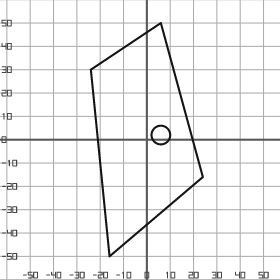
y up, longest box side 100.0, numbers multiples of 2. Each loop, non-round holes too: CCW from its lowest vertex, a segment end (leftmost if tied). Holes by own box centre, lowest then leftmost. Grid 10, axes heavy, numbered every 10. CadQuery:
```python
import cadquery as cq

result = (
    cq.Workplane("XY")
    .moveTo(-16.0, -50.0)
    .lineTo(24.0, -16.0)
    .lineTo(6.0, 50.0)
    .lineTo(-24.0, 30.0)
    .close()
    .moveTo(6.0, 2.0)
    .circle(4.0)
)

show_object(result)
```